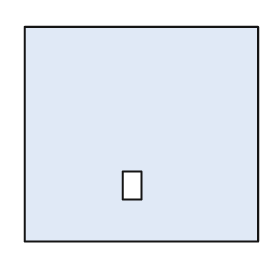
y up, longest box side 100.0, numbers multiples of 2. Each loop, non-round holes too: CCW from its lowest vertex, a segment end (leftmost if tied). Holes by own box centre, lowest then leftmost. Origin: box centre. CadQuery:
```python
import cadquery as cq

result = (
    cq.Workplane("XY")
    .moveTo(-50.0, -46.0)
    .lineTo(50.0, -46.0)
    .lineTo(50.0, 46.0)
    .lineTo(-50.0, 46.0)
    .close()
    .moveTo(-8.0, -28.0)
    .lineTo(0.0, -28.0)
    .lineTo(0.0, -16.0)
    .lineTo(-8.0, -16.0)
    .close()
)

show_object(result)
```